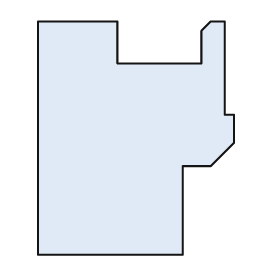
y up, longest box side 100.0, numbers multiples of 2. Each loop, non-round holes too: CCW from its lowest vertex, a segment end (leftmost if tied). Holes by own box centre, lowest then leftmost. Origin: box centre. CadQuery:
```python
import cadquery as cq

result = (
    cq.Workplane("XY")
    .moveTo(-42.0, -50.0)
    .lineTo(20.0, -50.0)
    .lineTo(20.0, -12.0)
    .lineTo(32.0, -12.0)
    .lineTo(42.0, -2.0)
    .lineTo(42.0, 10.0)
    .lineTo(38.0, 10.0)
    .lineTo(38.0, 50.0)
    .lineTo(32.0, 50.0)
    .lineTo(28.0, 46.0)
    .lineTo(28.0, 32.0)
    .lineTo(-8.0, 32.0)
    .lineTo(-8.0, 50.0)
    .lineTo(-42.0, 50.0)
    .close()
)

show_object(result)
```